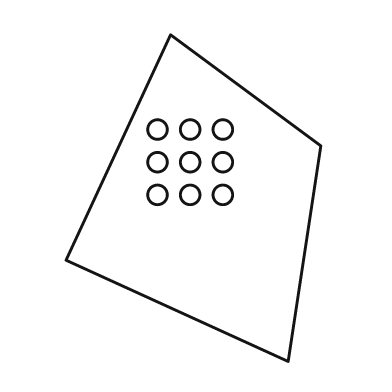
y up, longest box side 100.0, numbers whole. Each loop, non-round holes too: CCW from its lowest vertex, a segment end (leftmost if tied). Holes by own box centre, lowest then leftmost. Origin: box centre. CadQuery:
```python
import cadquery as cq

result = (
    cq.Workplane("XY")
    .moveTo(29.0, -50.0)
    .lineTo(39.0, 16.0)
    .lineTo(-7.0, 50.0)
    .lineTo(-39.0, -19.0)
    .close()
    .moveTo(-11.0, 1.0)
    .circle(3.0)
    .moveTo(-1.0, 1.0)
    .circle(3.0)
    .moveTo(9.0, 1.0)
    .circle(3.0)
    .moveTo(-11.0, 11.0)
    .circle(3.0)
    .moveTo(-1.0, 11.0)
    .circle(3.0)
    .moveTo(9.0, 11.0)
    .circle(3.0)
    .moveTo(-11.0, 21.0)
    .circle(3.0)
    .moveTo(-1.0, 21.0)
    .circle(3.0)
    .moveTo(9.0, 21.0)
    .circle(3.0)
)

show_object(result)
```